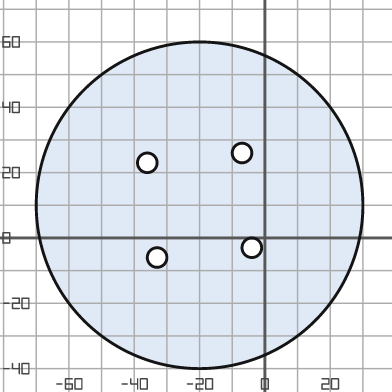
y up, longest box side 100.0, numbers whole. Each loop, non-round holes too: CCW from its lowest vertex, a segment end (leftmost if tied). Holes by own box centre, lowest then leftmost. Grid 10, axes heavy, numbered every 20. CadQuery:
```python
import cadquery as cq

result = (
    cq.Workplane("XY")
    .moveTo(-20.0, 10.0)
    .circle(50.0)
    .moveTo(-33.0, -6.0)
    .circle(3.0)
    .moveTo(-4.0, -3.0)
    .circle(3.0)
    .moveTo(-36.0, 23.0)
    .circle(3.0)
    .moveTo(-7.0, 26.0)
    .circle(3.0)
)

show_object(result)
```